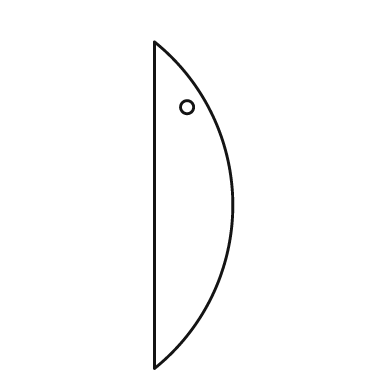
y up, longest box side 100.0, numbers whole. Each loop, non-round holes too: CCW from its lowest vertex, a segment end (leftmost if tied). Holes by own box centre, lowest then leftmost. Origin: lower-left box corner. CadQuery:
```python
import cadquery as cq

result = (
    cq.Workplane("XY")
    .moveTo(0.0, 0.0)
    .threePointArc((24.0, 50.0), (0.0, 100.0))
    .close()
    .moveTo(10.0, 80.0)
    .circle(2.0)
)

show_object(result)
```